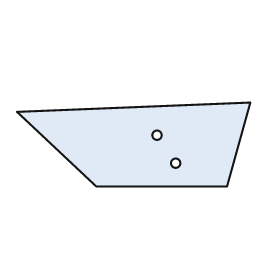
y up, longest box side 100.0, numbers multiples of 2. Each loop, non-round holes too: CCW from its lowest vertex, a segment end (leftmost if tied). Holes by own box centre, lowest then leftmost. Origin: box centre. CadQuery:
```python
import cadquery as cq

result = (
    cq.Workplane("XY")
    .moveTo(-16.0, -18.0)
    .lineTo(40.0, -18.0)
    .lineTo(50.0, 18.0)
    .lineTo(-50.0, 14.0)
    .close()
    .moveTo(18.0, -8.0)
    .circle(2.0)
    .moveTo(10.0, 4.0)
    .circle(2.0)
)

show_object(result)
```